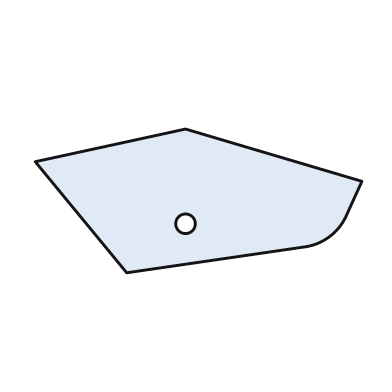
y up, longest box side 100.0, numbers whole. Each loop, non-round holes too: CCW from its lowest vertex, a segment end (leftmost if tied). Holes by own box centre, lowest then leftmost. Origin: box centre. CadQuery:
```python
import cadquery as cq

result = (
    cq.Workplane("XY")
    .moveTo(-22.0, -22.0)
    .lineTo(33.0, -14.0)
    .threePointArc((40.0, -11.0), (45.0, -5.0))
    .lineTo(50.0, 6.0)
    .lineTo(-4.0, 22.0)
    .lineTo(-50.0, 12.0)
    .close()
    .moveTo(-4.0, -7.0)
    .circle(3.0)
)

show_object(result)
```